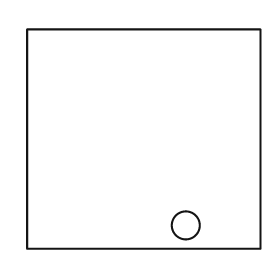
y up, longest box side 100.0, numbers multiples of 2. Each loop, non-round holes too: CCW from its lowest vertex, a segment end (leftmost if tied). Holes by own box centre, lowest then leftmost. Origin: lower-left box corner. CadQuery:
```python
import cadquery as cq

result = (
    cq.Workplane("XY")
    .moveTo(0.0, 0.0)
    .lineTo(100.0, 0.0)
    .lineTo(100.0, 94.0)
    .lineTo(0.0, 94.0)
    .close()
    .moveTo(68.0, 10.0)
    .circle(6.0)
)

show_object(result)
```